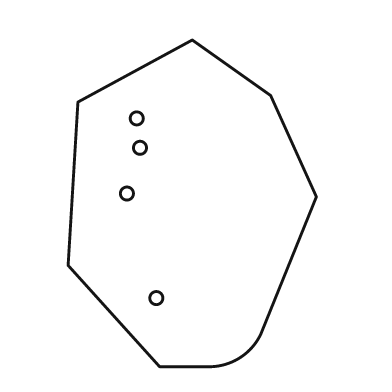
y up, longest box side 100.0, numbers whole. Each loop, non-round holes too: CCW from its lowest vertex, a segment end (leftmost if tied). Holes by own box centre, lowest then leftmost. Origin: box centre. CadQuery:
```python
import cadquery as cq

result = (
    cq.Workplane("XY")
    .moveTo(-10.0, -50.0)
    .lineTo(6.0, -50.0)
    .threePointArc((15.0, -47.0), (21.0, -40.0))
    .lineTo(38.0, 2.0)
    .lineTo(24.0, 33.0)
    .lineTo(0.0, 50.0)
    .lineTo(-35.0, 31.0)
    .lineTo(-38.0, -19.0)
    .close()
    .moveTo(-11.0, -29.0)
    .circle(2.0)
    .moveTo(-20.0, 3.0)
    .circle(2.0)
    .moveTo(-16.0, 17.0)
    .circle(2.0)
    .moveTo(-17.0, 26.0)
    .circle(2.0)
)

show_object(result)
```